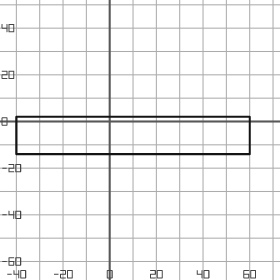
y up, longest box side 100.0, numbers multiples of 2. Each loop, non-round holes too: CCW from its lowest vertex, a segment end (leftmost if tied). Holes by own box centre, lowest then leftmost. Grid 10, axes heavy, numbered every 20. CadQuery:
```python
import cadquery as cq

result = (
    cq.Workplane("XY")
    .moveTo(-40.0, -14.0)
    .lineTo(60.0, -14.0)
    .lineTo(60.0, 2.0)
    .lineTo(-40.0, 2.0)
    .close()
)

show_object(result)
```